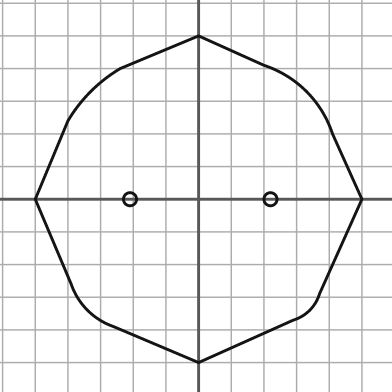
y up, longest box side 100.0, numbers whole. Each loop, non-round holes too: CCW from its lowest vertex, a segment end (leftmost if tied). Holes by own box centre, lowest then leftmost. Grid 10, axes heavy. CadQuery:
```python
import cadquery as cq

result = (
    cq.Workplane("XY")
    .moveTo(0.0, -50.0)
    .lineTo(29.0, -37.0)
    .threePointArc((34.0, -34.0), (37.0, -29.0))
    .lineTo(50.0, 0.0)
    .lineTo(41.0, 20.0)
    .threePointArc((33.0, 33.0), (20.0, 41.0))
    .lineTo(0.0, 50.0)
    .lineTo(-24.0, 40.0)
    .threePointArc((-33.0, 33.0), (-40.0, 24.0))
    .lineTo(-50.0, 0.0)
    .lineTo(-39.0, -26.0)
    .threePointArc((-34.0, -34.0), (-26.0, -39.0))
    .close()
    .moveTo(-21.0, 0.0)
    .circle(2.0)
    .moveTo(22.0, 0.0)
    .circle(2.0)
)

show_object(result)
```